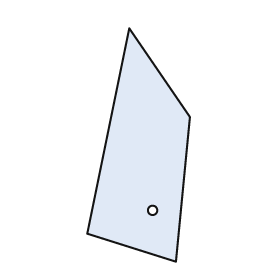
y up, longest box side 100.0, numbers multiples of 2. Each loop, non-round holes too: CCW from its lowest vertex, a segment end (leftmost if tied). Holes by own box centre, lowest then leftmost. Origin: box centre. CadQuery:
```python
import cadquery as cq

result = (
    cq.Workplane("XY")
    .moveTo(16.0, -50.0)
    .lineTo(22.0, 12.0)
    .lineTo(-4.0, 50.0)
    .lineTo(-22.0, -38.0)
    .close()
    .moveTo(6.0, -28.0)
    .circle(2.0)
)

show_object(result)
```